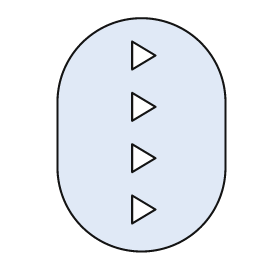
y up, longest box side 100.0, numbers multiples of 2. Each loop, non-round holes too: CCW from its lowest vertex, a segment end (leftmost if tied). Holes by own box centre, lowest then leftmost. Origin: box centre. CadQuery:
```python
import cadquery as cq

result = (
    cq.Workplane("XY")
    .moveTo(-36.0, -14.0)
    .threePointArc((0.0, -50.0), (36.0, -14.0))
    .lineTo(36.0, 14.0)
    .threePointArc((0.0, 50.0), (-36.0, 14.0))
    .close()
    .moveTo(-4.0, -38.0)
    .lineTo(6.0, -32.0)
    .lineTo(-4.0, -26.0)
    .close()
    .moveTo(-4.0, -16.0)
    .lineTo(6.0, -10.0)
    .lineTo(-4.0, -4.0)
    .close()
    .moveTo(-4.0, 6.0)
    .lineTo(6.0, 12.0)
    .lineTo(-4.0, 18.0)
    .close()
    .moveTo(-4.0, 28.0)
    .lineTo(6.0, 34.0)
    .lineTo(-4.0, 40.0)
    .close()
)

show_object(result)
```